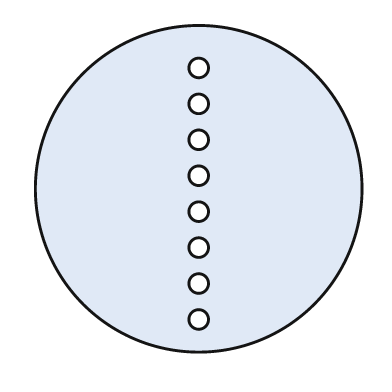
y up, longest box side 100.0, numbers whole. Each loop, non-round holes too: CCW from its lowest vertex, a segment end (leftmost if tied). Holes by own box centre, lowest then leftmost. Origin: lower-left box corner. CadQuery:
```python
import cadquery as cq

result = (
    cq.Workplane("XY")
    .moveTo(50.0, 50.0)
    .circle(50.0)
    .moveTo(50.0, 10.0)
    .circle(3.0)
    .moveTo(50.0, 21.0)
    .circle(3.0)
    .moveTo(50.0, 32.0)
    .circle(3.0)
    .moveTo(50.0, 43.0)
    .circle(3.0)
    .moveTo(50.0, 54.0)
    .circle(3.0)
    .moveTo(50.0, 65.0)
    .circle(3.0)
    .moveTo(50.0, 76.0)
    .circle(3.0)
    .moveTo(50.0, 87.0)
    .circle(3.0)
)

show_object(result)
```